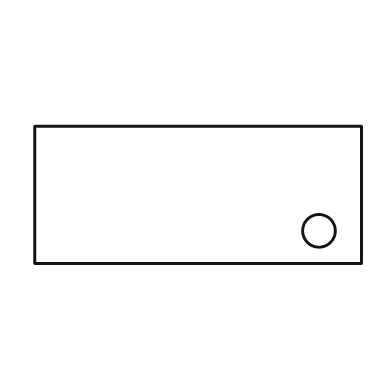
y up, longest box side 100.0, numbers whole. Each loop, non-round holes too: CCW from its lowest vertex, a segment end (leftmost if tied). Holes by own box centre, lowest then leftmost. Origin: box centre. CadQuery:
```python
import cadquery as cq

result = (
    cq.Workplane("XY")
    .moveTo(-50.0, -21.0)
    .lineTo(50.0, -21.0)
    .lineTo(50.0, 21.0)
    .lineTo(-50.0, 21.0)
    .close()
    .moveTo(37.0, -11.0)
    .circle(5.0)
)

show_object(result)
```